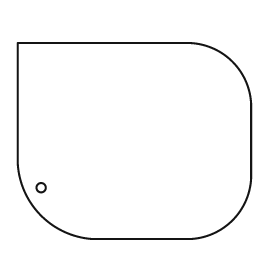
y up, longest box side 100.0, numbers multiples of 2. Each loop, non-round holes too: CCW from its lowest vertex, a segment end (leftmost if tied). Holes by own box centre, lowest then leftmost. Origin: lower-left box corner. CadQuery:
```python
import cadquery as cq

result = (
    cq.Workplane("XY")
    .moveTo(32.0, 0.0)
    .lineTo(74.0, 0.0)
    .threePointArc((92.0, 8.0), (100.0, 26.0))
    .lineTo(100.0, 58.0)
    .threePointArc((92.0, 76.0), (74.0, 84.0))
    .lineTo(0.0, 84.0)
    .lineTo(0.0, 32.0)
    .threePointArc((10.0, 10.0), (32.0, 0.0))
    .close()
    .moveTo(10.0, 22.0)
    .circle(2.0)
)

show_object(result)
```